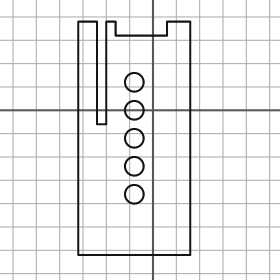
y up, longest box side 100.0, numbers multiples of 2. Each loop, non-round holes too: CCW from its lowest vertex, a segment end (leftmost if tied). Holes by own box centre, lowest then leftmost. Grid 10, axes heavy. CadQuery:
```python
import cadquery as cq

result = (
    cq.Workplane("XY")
    .moveTo(-32.0, -62.0)
    .lineTo(16.0, -62.0)
    .lineTo(16.0, 38.0)
    .lineTo(6.0, 38.0)
    .lineTo(6.0, 32.0)
    .lineTo(-16.0, 32.0)
    .lineTo(-16.0, 38.0)
    .lineTo(-20.0, 38.0)
    .lineTo(-20.0, -6.0)
    .lineTo(-24.0, -6.0)
    .lineTo(-24.0, 38.0)
    .lineTo(-32.0, 38.0)
    .close()
    .moveTo(-8.0, -36.0)
    .circle(4.0)
    .moveTo(-8.0, -24.0)
    .circle(4.0)
    .moveTo(-8.0, -12.0)
    .circle(4.0)
    .moveTo(-8.0, 0.0)
    .circle(4.0)
    .moveTo(-8.0, 12.0)
    .circle(4.0)
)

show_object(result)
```